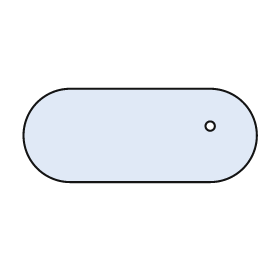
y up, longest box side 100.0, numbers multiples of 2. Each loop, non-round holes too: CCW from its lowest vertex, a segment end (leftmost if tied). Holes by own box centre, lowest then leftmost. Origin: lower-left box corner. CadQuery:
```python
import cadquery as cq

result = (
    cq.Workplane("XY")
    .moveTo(20.0, 0.0)
    .lineTo(80.0, 0.0)
    .threePointArc((100.0, 20.0), (80.0, 40.0))
    .lineTo(20.0, 40.0)
    .threePointArc((0.0, 20.0), (20.0, 0.0))
    .close()
    .moveTo(80.0, 24.0)
    .circle(2.0)
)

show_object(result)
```